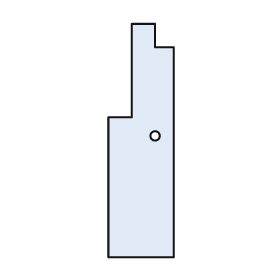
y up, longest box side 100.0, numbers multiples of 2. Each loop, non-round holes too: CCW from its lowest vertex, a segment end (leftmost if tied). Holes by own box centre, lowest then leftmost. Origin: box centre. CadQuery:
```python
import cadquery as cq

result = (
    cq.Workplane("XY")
    .moveTo(-14.0, -50.0)
    .lineTo(14.0, -50.0)
    .lineTo(14.0, 40.0)
    .lineTo(6.0, 40.0)
    .lineTo(6.0, 50.0)
    .lineTo(-4.0, 50.0)
    .lineTo(-4.0, 10.0)
    .lineTo(-14.0, 10.0)
    .close()
    .moveTo(6.0, 2.0)
    .circle(2.0)
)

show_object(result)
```